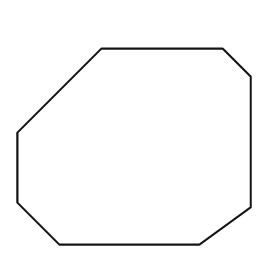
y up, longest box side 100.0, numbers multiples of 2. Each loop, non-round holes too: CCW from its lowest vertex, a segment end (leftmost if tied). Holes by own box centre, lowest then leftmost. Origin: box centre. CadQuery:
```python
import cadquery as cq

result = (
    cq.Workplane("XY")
    .moveTo(-32.0, -42.0)
    .lineTo(28.0, -42.0)
    .lineTo(50.0, -26.0)
    .lineTo(50.0, 30.0)
    .lineTo(38.0, 42.0)
    .lineTo(-14.0, 42.0)
    .lineTo(-50.0, 6.0)
    .lineTo(-50.0, -24.0)
    .close()
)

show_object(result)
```